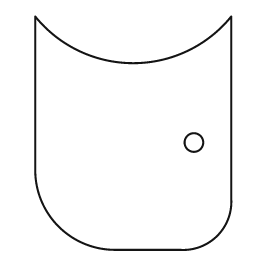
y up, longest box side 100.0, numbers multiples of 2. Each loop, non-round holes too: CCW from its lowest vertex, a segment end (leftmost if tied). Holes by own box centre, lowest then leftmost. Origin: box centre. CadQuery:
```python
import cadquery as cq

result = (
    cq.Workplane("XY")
    .moveTo(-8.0, -50.0)
    .lineTo(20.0, -50.0)
    .threePointArc((36.0, -44.0), (42.0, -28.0))
    .lineTo(42.0, 50.0)
    .threePointArc((0.0, 30.0), (-42.0, 50.0))
    .lineTo(-42.0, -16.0)
    .threePointArc((-32.0, -40.0), (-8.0, -50.0))
    .close()
    .moveTo(26.0, -4.0)
    .circle(4.0)
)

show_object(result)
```